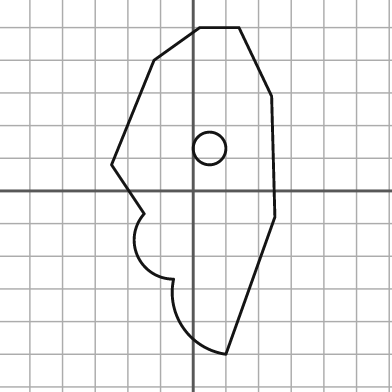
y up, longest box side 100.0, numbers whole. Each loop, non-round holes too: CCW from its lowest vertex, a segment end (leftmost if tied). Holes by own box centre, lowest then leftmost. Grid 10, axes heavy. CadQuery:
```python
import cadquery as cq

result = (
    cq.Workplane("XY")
    .moveTo(10.0, -50.0)
    .lineTo(25.0, -8.0)
    .lineTo(24.0, 29.0)
    .lineTo(14.0, 50.0)
    .lineTo(2.0, 50.0)
    .lineTo(-12.0, 40.0)
    .lineTo(-25.0, 8.0)
    .lineTo(-15.0, -7.0)
    .threePointArc((-17.0, -20.0), (-6.0, -27.0))
    .threePointArc((-3.0, -42.0), (10.0, -50.0))
    .close()
    .moveTo(5.0, 13.0)
    .circle(5.0)
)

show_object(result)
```